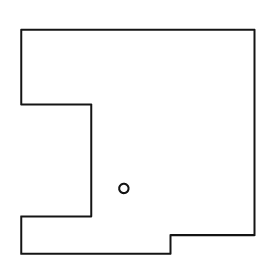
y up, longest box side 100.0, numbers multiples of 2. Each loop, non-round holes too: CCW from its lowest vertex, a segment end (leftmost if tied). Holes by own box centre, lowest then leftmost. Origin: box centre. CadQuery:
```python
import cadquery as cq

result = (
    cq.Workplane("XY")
    .moveTo(-50.0, -48.0)
    .lineTo(14.0, -48.0)
    .lineTo(14.0, -40.0)
    .lineTo(50.0, -40.0)
    .lineTo(50.0, 48.0)
    .lineTo(-50.0, 48.0)
    .lineTo(-50.0, 16.0)
    .lineTo(-20.0, 16.0)
    .lineTo(-20.0, -32.0)
    .lineTo(-50.0, -32.0)
    .close()
    .moveTo(-6.0, -20.0)
    .circle(2.0)
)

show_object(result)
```